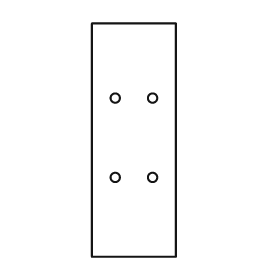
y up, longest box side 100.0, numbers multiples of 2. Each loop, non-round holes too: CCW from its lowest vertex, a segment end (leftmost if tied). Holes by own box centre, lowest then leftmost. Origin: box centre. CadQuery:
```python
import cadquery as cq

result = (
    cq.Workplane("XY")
    .moveTo(-18.0, -50.0)
    .lineTo(18.0, -50.0)
    .lineTo(18.0, 50.0)
    .lineTo(-18.0, 50.0)
    .close()
    .moveTo(-8.0, -16.0)
    .circle(2.0)
    .moveTo(8.0, -16.0)
    .circle(2.0)
    .moveTo(-8.0, 18.0)
    .circle(2.0)
    .moveTo(8.0, 18.0)
    .circle(2.0)
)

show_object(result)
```